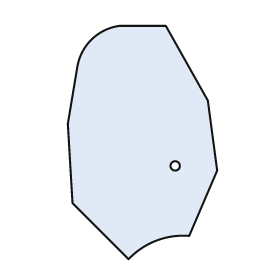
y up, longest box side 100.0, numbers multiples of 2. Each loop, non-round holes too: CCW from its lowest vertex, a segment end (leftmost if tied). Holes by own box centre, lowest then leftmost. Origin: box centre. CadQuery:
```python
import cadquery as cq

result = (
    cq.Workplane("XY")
    .moveTo(-6.0, -50.0)
    .threePointArc((6.0, -42.0), (20.0, -40.0))
    .lineTo(32.0, -12.0)
    .lineTo(28.0, 18.0)
    .lineTo(10.0, 50.0)
    .lineTo(-10.0, 50.0)
    .threePointArc((-22.0, 44.0), (-28.0, 32.0))
    .lineTo(-32.0, 8.0)
    .lineTo(-30.0, -26.0)
    .close()
    .moveTo(14.0, -10.0)
    .circle(2.0)
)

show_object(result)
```